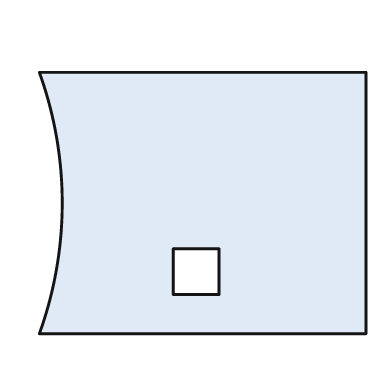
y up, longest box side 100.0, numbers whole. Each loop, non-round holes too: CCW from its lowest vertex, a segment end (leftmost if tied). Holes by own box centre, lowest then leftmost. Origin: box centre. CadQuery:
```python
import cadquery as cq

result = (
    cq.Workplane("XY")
    .moveTo(-50.0, -40.0)
    .lineTo(50.0, -40.0)
    .lineTo(50.0, 40.0)
    .lineTo(-50.0, 40.0)
    .threePointArc((-43.0, 0.0), (-50.0, -40.0))
    .close()
    .moveTo(-9.0, -28.0)
    .lineTo(5.0, -28.0)
    .lineTo(5.0, -14.0)
    .lineTo(-9.0, -14.0)
    .close()
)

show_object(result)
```